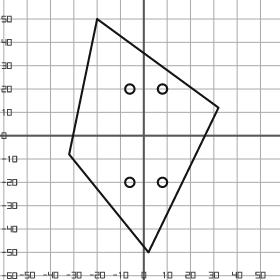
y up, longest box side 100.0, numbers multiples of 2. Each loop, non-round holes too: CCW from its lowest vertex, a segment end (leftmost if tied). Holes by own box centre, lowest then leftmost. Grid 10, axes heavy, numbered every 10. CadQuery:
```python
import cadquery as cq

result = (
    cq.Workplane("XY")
    .moveTo(2.0, -50.0)
    .lineTo(32.0, 12.0)
    .lineTo(-20.0, 50.0)
    .lineTo(-32.0, -8.0)
    .close()
    .moveTo(-6.0, -20.0)
    .circle(2.0)
    .moveTo(8.0, -20.0)
    .circle(2.0)
    .moveTo(-6.0, 20.0)
    .circle(2.0)
    .moveTo(8.0, 20.0)
    .circle(2.0)
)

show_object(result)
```